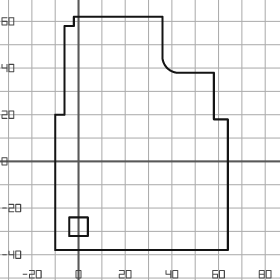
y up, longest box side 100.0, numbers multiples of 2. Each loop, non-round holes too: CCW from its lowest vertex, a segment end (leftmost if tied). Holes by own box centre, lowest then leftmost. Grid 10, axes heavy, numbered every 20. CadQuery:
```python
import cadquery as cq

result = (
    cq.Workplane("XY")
    .moveTo(-10.0, -38.0)
    .lineTo(64.0, -38.0)
    .lineTo(64.0, 18.0)
    .lineTo(58.0, 18.0)
    .lineTo(58.0, 38.0)
    .lineTo(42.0, 38.0)
    .threePointArc((38.0, 40.0), (36.0, 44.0))
    .lineTo(36.0, 62.0)
    .lineTo(-2.0, 62.0)
    .lineTo(-2.0, 58.0)
    .lineTo(-6.0, 58.0)
    .lineTo(-6.0, 20.0)
    .lineTo(-10.0, 20.0)
    .close()
    .moveTo(-4.0, -32.0)
    .lineTo(4.0, -32.0)
    .lineTo(4.0, -24.0)
    .lineTo(-4.0, -24.0)
    .close()
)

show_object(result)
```